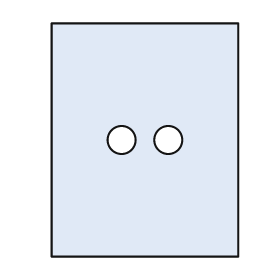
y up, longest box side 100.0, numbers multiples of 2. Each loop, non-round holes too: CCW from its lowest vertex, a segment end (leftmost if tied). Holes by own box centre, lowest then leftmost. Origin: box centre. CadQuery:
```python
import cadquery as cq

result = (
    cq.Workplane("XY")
    .moveTo(-40.0, -50.0)
    .lineTo(40.0, -50.0)
    .lineTo(40.0, 50.0)
    .lineTo(-40.0, 50.0)
    .close()
    .moveTo(-10.0, 0.0)
    .circle(6.0)
    .moveTo(10.0, 0.0)
    .circle(6.0)
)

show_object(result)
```